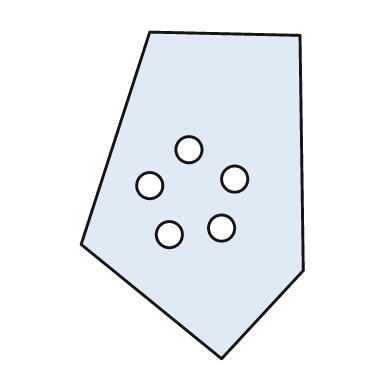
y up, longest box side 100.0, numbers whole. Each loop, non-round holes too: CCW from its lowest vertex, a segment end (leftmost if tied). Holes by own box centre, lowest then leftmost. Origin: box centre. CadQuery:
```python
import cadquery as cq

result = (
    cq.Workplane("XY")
    .moveTo(9.0, -50.0)
    .lineTo(34.0, -23.0)
    .lineTo(33.0, 49.0)
    .lineTo(-13.0, 50.0)
    .lineTo(-34.0, -15.0)
    .close()
    .moveTo(-7.0, -12.0)
    .circle(4.0)
    .moveTo(9.0, -10.0)
    .circle(4.0)
    .moveTo(-13.0, 3.0)
    .circle(4.0)
    .moveTo(13.0, 5.0)
    .circle(4.0)
    .moveTo(-1.0, 14.0)
    .circle(4.0)
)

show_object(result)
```